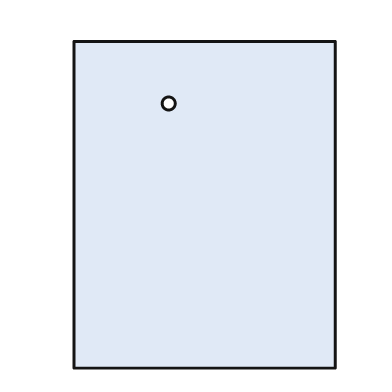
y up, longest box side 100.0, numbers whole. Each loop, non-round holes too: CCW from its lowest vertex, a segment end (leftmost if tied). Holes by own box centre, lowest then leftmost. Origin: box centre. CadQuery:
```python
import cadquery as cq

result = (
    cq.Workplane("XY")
    .moveTo(-40.0, -50.0)
    .lineTo(40.0, -50.0)
    .lineTo(40.0, 50.0)
    .lineTo(-40.0, 50.0)
    .close()
    .moveTo(-11.0, 31.0)
    .circle(2.0)
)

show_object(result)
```